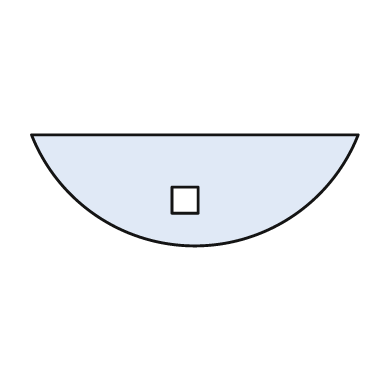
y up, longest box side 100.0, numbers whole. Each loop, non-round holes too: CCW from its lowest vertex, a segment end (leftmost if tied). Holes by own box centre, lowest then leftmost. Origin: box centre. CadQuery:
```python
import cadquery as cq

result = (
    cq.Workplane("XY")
    .moveTo(-50.0, 17.0)
    .threePointArc((0.0, -17.0), (50.0, 17.0))
    .close()
    .moveTo(-7.0, -7.0)
    .lineTo(1.0, -7.0)
    .lineTo(1.0, 1.0)
    .lineTo(-7.0, 1.0)
    .close()
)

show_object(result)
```